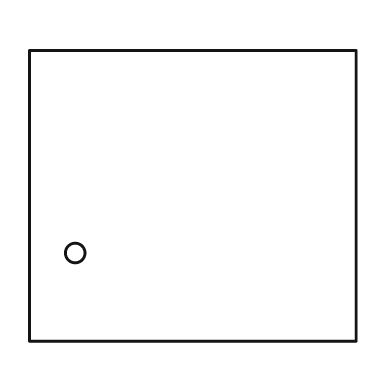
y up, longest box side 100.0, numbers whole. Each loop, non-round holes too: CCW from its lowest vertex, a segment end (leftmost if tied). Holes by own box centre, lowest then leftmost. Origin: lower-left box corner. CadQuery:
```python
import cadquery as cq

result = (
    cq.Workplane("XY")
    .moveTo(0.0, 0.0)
    .lineTo(100.0, 0.0)
    .lineTo(100.0, 89.0)
    .lineTo(0.0, 89.0)
    .close()
    .moveTo(14.0, 27.0)
    .circle(3.0)
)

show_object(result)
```